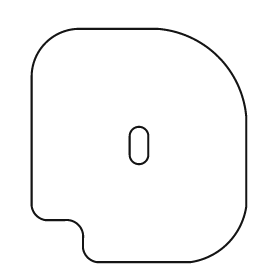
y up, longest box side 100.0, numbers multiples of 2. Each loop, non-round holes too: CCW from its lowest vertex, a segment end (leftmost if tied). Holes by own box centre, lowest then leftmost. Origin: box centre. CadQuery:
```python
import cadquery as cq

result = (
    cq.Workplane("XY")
    .moveTo(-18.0, -50.0)
    .lineTo(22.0, -50.0)
    .threePointArc((38.0, -42.0), (46.0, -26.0))
    .lineTo(46.0, 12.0)
    .threePointArc((34.0, 38.0), (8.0, 50.0))
    .lineTo(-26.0, 50.0)
    .threePointArc((-40.0, 44.0), (-46.0, 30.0))
    .lineTo(-46.0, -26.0)
    .threePointArc((-44.0, -30.0), (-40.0, -32.0))
    .lineTo(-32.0, -32.0)
    .threePointArc((-26.0, -34.0), (-24.0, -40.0))
    .lineTo(-24.0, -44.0)
    .threePointArc((-22.0, -48.0), (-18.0, -50.0))
    .close()
    .moveTo(-4.0, -4.0)
    .threePointArc((0.0, -8.0), (4.0, -4.0))
    .lineTo(4.0, 4.0)
    .threePointArc((0.0, 8.0), (-4.0, 4.0))
    .close()
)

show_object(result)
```